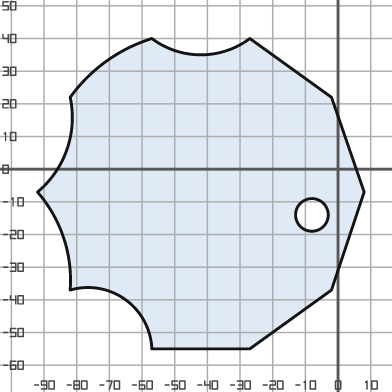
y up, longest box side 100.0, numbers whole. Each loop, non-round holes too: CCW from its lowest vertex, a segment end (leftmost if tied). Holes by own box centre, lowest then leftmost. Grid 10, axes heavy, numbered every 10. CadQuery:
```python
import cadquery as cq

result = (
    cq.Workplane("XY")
    .moveTo(-57.0, -55.0)
    .lineTo(-27.0, -55.0)
    .lineTo(-2.0, -37.0)
    .lineTo(8.0, -7.0)
    .lineTo(-2.0, 22.0)
    .lineTo(-27.0, 40.0)
    .threePointArc((-42.0, 35.0), (-57.0, 40.0))
    .threePointArc((-71.0, 33.0), (-82.0, 22.0))
    .threePointArc((-83.0, 6.0), (-92.0, -7.0))
    .threePointArc((-84.0, -21.0), (-82.0, -37.0))
    .threePointArc((-65.0, -40.0), (-57.0, -55.0))
    .close()
    .moveTo(-8.0, -14.0)
    .circle(5.0)
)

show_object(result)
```